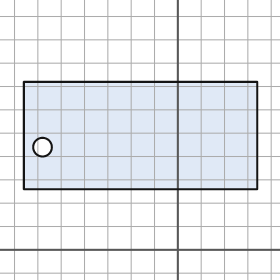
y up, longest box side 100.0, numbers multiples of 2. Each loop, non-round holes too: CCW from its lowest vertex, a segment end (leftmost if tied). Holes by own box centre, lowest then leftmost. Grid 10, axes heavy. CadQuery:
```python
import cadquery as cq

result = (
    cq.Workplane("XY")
    .moveTo(-66.0, 26.0)
    .lineTo(34.0, 26.0)
    .lineTo(34.0, 72.0)
    .lineTo(-66.0, 72.0)
    .close()
    .moveTo(-58.0, 44.0)
    .circle(4.0)
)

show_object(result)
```